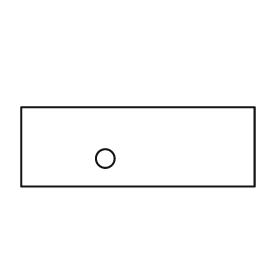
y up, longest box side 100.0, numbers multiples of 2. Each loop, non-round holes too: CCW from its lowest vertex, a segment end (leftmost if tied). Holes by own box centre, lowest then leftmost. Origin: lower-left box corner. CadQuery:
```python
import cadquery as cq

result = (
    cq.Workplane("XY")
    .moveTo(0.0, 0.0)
    .lineTo(100.0, 0.0)
    .lineTo(100.0, 34.0)
    .lineTo(0.0, 34.0)
    .close()
    .moveTo(36.0, 12.0)
    .circle(4.0)
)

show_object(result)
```